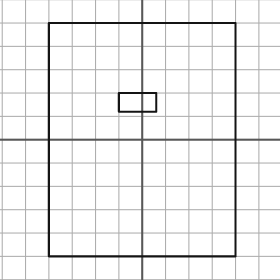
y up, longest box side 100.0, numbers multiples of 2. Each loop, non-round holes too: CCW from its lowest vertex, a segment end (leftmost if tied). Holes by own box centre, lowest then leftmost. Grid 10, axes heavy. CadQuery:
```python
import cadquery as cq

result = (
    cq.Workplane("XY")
    .moveTo(-40.0, -50.0)
    .lineTo(40.0, -50.0)
    .lineTo(40.0, 50.0)
    .lineTo(-40.0, 50.0)
    .close()
    .moveTo(-10.0, 12.0)
    .lineTo(6.0, 12.0)
    .lineTo(6.0, 20.0)
    .lineTo(-10.0, 20.0)
    .close()
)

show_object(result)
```